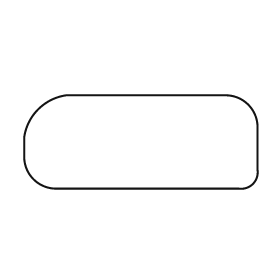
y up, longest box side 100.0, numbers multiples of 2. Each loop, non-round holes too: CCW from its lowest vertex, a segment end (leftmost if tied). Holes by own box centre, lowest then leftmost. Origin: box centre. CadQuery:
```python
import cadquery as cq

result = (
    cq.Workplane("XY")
    .moveTo(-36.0, -20.0)
    .lineTo(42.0, -20.0)
    .threePointArc((48.0, -18.0), (50.0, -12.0))
    .lineTo(50.0, 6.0)
    .threePointArc((46.0, 16.0), (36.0, 20.0))
    .lineTo(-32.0, 20.0)
    .threePointArc((-44.0, 14.0), (-50.0, 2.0))
    .lineTo(-50.0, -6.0)
    .threePointArc((-46.0, -16.0), (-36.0, -20.0))
    .close()
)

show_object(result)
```